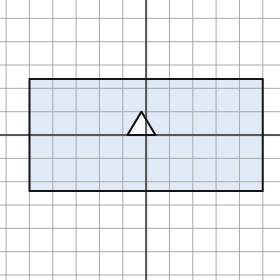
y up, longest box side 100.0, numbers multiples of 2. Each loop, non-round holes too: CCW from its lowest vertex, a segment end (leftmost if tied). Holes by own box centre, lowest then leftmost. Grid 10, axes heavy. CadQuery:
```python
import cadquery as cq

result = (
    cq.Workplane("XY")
    .moveTo(-50.0, -24.0)
    .lineTo(50.0, -24.0)
    .lineTo(50.0, 24.0)
    .lineTo(-50.0, 24.0)
    .close()
    .moveTo(-8.0, 0.0)
    .lineTo(4.0, 0.0)
    .lineTo(-2.0, 10.0)
    .close()
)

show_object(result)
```